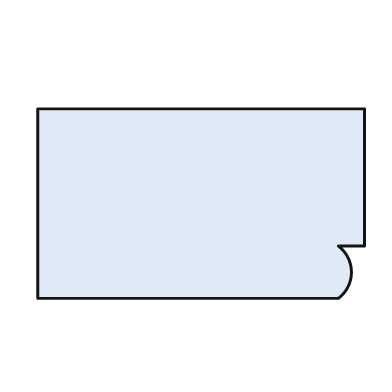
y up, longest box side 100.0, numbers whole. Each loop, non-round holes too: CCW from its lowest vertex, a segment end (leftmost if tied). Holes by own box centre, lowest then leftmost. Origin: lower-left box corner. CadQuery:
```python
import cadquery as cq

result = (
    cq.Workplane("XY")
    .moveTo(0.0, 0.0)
    .lineTo(92.0, 0.0)
    .threePointArc((96.0, 8.0), (92.0, 16.0))
    .lineTo(100.0, 16.0)
    .lineTo(100.0, 58.0)
    .lineTo(0.0, 58.0)
    .close()
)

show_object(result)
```